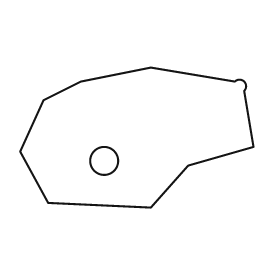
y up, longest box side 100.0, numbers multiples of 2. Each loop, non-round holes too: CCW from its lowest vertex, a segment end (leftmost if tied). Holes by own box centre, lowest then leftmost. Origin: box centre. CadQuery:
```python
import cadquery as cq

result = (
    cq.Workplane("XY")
    .moveTo(6.0, -30.0)
    .lineTo(22.0, -12.0)
    .lineTo(50.0, -4.0)
    .lineTo(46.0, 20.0)
    .threePointArc((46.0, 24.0), (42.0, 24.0))
    .lineTo(6.0, 30.0)
    .lineTo(-24.0, 24.0)
    .lineTo(-40.0, 16.0)
    .lineTo(-50.0, -6.0)
    .lineTo(-38.0, -28.0)
    .close()
    .moveTo(-14.0, -10.0)
    .circle(6.0)
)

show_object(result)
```